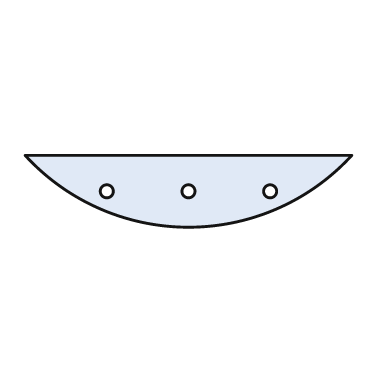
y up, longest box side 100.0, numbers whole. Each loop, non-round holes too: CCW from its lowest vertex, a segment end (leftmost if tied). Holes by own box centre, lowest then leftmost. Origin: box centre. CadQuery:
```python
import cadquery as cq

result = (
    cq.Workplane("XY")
    .moveTo(-50.0, 11.0)
    .threePointArc((0.0, -11.0), (50.0, 11.0))
    .close()
    .moveTo(-25.0, 0.0)
    .circle(2.0)
    .moveTo(0.0, 0.0)
    .circle(2.0)
    .moveTo(25.0, 0.0)
    .circle(2.0)
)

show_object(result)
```